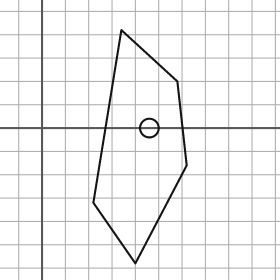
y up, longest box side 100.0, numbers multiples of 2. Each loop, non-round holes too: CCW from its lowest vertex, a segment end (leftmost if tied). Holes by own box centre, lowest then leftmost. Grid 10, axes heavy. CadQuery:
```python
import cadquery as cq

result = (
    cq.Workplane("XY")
    .moveTo(40.0, -58.0)
    .lineTo(62.0, -16.0)
    .lineTo(58.0, 20.0)
    .lineTo(34.0, 42.0)
    .lineTo(22.0, -32.0)
    .close()
    .moveTo(46.0, 0.0)
    .circle(4.0)
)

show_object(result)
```